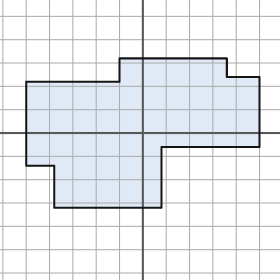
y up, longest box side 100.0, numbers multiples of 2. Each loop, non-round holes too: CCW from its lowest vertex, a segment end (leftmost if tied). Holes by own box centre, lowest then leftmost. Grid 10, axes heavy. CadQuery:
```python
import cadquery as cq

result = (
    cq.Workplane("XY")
    .moveTo(-38.0, -32.0)
    .lineTo(8.0, -32.0)
    .lineTo(8.0, -6.0)
    .lineTo(50.0, -6.0)
    .lineTo(50.0, 24.0)
    .lineTo(36.0, 24.0)
    .lineTo(36.0, 32.0)
    .lineTo(-10.0, 32.0)
    .lineTo(-10.0, 22.0)
    .lineTo(-50.0, 22.0)
    .lineTo(-50.0, -14.0)
    .lineTo(-38.0, -14.0)
    .close()
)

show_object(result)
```